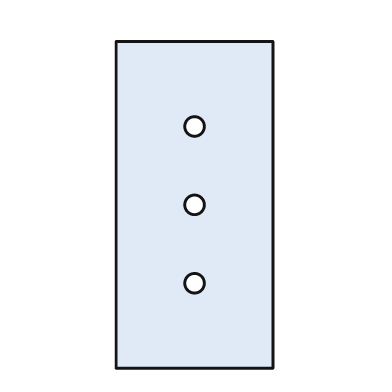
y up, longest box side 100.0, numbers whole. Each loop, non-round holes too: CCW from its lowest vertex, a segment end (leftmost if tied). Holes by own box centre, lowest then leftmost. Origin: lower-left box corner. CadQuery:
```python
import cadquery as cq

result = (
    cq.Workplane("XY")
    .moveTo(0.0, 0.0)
    .lineTo(48.0, 0.0)
    .lineTo(48.0, 100.0)
    .lineTo(0.0, 100.0)
    .close()
    .moveTo(24.0, 26.0)
    .circle(3.0)
    .moveTo(24.0, 50.0)
    .circle(3.0)
    .moveTo(24.0, 74.0)
    .circle(3.0)
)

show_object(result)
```